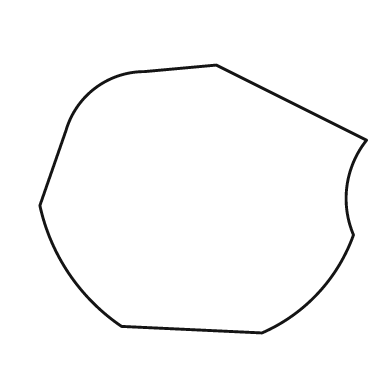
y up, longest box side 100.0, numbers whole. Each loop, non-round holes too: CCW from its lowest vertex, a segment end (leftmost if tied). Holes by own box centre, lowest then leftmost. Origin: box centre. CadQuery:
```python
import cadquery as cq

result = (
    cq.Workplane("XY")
    .moveTo(18.0, -41.0)
    .threePointArc((35.0, -29.0), (46.0, -11.0))
    .threePointArc((44.0, 4.0), (50.0, 18.0))
    .lineTo(4.0, 41.0)
    .lineTo(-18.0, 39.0)
    .threePointArc((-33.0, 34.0), (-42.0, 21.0))
    .lineTo(-50.0, -2.0)
    .threePointArc((-41.0, -23.0), (-25.0, -39.0))
    .close()
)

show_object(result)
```